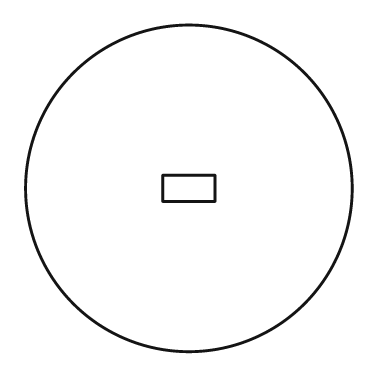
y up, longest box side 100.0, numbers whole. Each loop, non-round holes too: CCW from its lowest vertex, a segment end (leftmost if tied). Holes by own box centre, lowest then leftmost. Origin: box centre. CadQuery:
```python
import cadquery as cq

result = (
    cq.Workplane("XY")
    .moveTo(0.0, 0.0)
    .circle(50.0)
    .moveTo(-8.0, -4.0)
    .lineTo(8.0, -4.0)
    .lineTo(8.0, 4.0)
    .lineTo(-8.0, 4.0)
    .close()
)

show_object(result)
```